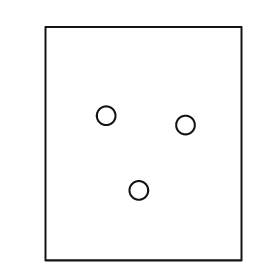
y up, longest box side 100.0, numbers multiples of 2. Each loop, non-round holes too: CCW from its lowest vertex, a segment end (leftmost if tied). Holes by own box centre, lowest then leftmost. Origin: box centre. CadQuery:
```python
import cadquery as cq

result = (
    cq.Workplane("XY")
    .moveTo(-42.0, -50.0)
    .lineTo(42.0, -50.0)
    .lineTo(42.0, 50.0)
    .lineTo(-42.0, 50.0)
    .close()
    .moveTo(-2.0, -20.0)
    .circle(4.0)
    .moveTo(18.0, 8.0)
    .circle(4.0)
    .moveTo(-16.0, 12.0)
    .circle(4.0)
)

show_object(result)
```